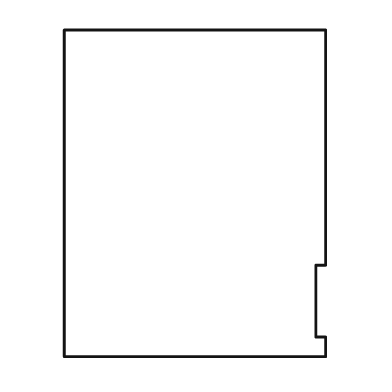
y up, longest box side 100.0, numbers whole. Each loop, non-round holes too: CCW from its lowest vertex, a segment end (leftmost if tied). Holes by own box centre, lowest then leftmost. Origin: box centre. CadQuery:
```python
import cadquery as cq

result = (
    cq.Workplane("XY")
    .moveTo(-40.0, -50.0)
    .lineTo(40.0, -50.0)
    .lineTo(40.0, -44.0)
    .lineTo(37.0, -44.0)
    .lineTo(37.0, -22.0)
    .lineTo(40.0, -22.0)
    .lineTo(40.0, 50.0)
    .lineTo(-40.0, 50.0)
    .close()
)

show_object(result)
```